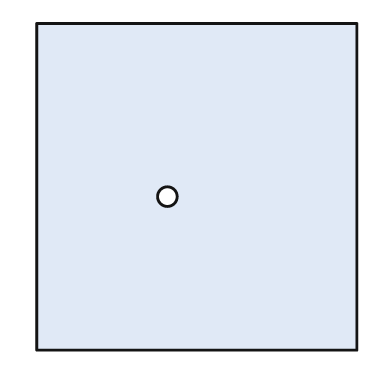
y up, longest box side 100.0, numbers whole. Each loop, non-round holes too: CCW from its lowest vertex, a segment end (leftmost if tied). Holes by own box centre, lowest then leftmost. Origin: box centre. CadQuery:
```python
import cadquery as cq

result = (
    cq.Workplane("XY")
    .moveTo(-49.0, -50.0)
    .lineTo(49.0, -50.0)
    .lineTo(49.0, 50.0)
    .lineTo(-49.0, 50.0)
    .close()
    .moveTo(-9.0, -3.0)
    .circle(3.0)
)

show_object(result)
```